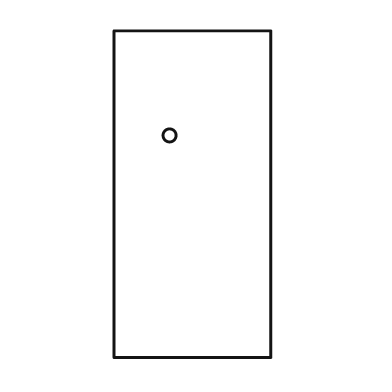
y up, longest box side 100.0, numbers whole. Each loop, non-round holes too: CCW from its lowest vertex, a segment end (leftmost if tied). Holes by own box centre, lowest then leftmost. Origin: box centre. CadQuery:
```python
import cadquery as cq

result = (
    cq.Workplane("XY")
    .moveTo(-24.0, -50.0)
    .lineTo(24.0, -50.0)
    .lineTo(24.0, 50.0)
    .lineTo(-24.0, 50.0)
    .close()
    .moveTo(-7.0, 18.0)
    .circle(2.0)
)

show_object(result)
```